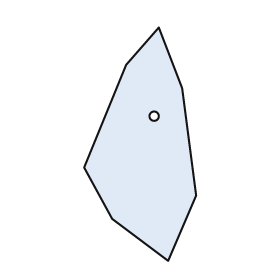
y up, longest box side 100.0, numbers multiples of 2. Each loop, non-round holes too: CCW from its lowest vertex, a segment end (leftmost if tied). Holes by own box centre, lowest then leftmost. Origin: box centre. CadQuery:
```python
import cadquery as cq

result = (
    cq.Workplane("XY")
    .moveTo(12.0, -50.0)
    .lineTo(24.0, -22.0)
    .lineTo(18.0, 24.0)
    .lineTo(8.0, 50.0)
    .lineTo(-6.0, 34.0)
    .lineTo(-24.0, -10.0)
    .lineTo(-12.0, -32.0)
    .close()
    .moveTo(6.0, 12.0)
    .circle(2.0)
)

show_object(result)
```